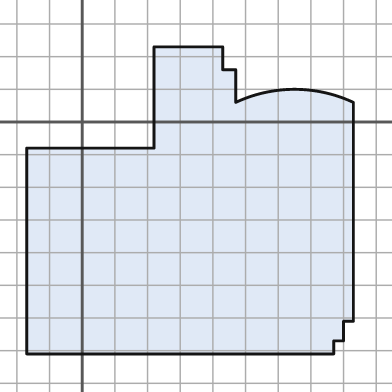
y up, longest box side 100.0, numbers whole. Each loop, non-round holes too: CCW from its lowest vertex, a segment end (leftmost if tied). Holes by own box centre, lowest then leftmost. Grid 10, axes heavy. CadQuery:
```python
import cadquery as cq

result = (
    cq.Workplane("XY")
    .moveTo(-17.0, -71.0)
    .lineTo(77.0, -71.0)
    .lineTo(77.0, -67.0)
    .lineTo(80.0, -67.0)
    .lineTo(80.0, -61.0)
    .lineTo(83.0, -61.0)
    .lineTo(83.0, 6.0)
    .threePointArc((65.0, 10.0), (47.0, 6.0))
    .lineTo(47.0, 16.0)
    .lineTo(43.0, 16.0)
    .lineTo(43.0, 23.0)
    .lineTo(22.0, 23.0)
    .lineTo(22.0, -8.0)
    .lineTo(-17.0, -8.0)
    .close()
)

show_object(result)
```